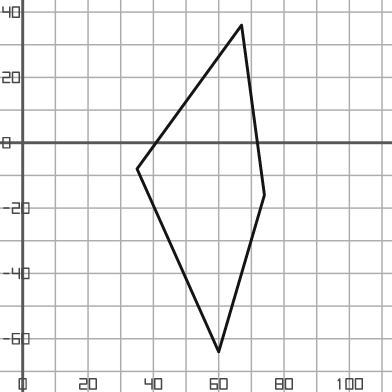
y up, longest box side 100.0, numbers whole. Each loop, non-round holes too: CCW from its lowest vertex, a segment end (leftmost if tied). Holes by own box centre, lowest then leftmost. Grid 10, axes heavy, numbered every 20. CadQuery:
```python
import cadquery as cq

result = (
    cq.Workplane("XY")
    .moveTo(60.0, -64.0)
    .lineTo(74.0, -16.0)
    .lineTo(67.0, 36.0)
    .lineTo(35.0, -8.0)
    .close()
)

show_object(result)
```